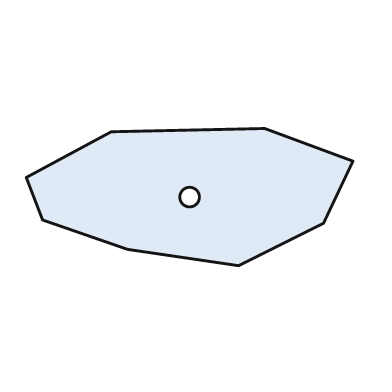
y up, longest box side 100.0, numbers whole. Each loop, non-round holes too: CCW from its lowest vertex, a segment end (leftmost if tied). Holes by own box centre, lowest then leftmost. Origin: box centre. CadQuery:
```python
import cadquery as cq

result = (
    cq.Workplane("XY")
    .moveTo(15.0, -21.0)
    .lineTo(41.0, -8.0)
    .lineTo(50.0, 11.0)
    .lineTo(23.0, 21.0)
    .lineTo(-24.0, 20.0)
    .lineTo(-50.0, 6.0)
    .lineTo(-45.0, -7.0)
    .lineTo(-19.0, -16.0)
    .close()
    .moveTo(0.0, 0.0)
    .circle(3.0)
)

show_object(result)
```